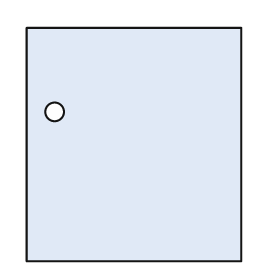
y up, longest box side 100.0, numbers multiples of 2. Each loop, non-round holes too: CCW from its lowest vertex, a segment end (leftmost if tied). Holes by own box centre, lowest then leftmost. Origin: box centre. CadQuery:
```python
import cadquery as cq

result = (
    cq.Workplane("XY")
    .moveTo(-46.0, -50.0)
    .lineTo(46.0, -50.0)
    .lineTo(46.0, 50.0)
    .lineTo(-46.0, 50.0)
    .close()
    .moveTo(-34.0, 14.0)
    .circle(4.0)
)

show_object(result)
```